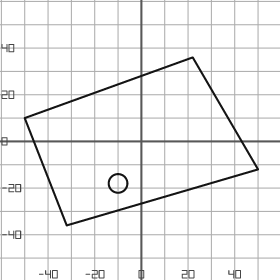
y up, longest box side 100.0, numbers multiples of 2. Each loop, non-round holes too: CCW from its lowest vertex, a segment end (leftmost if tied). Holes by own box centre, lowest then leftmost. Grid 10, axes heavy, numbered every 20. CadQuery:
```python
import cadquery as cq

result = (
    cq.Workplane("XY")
    .moveTo(-32.0, -36.0)
    .lineTo(50.0, -12.0)
    .lineTo(22.0, 36.0)
    .lineTo(-50.0, 10.0)
    .close()
    .moveTo(-10.0, -18.0)
    .circle(4.0)
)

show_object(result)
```